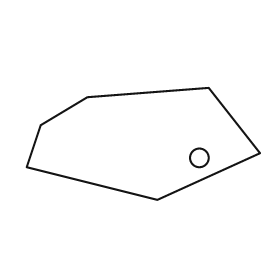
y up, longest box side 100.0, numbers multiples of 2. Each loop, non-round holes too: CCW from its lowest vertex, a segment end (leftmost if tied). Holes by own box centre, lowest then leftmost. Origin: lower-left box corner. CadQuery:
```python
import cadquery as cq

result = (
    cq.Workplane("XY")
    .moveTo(56.0, 0.0)
    .lineTo(100.0, 20.0)
    .lineTo(78.0, 48.0)
    .lineTo(26.0, 44.0)
    .lineTo(6.0, 32.0)
    .lineTo(0.0, 14.0)
    .close()
    .moveTo(74.0, 18.0)
    .circle(4.0)
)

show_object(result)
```